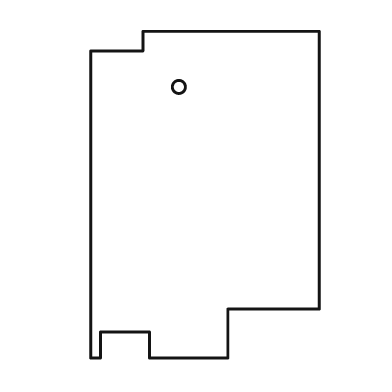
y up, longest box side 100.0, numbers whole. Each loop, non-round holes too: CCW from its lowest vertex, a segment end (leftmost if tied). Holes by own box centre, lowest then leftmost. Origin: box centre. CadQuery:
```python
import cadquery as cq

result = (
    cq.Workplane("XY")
    .moveTo(-35.0, -50.0)
    .lineTo(-32.0, -50.0)
    .lineTo(-32.0, -42.0)
    .lineTo(-17.0, -42.0)
    .lineTo(-17.0, -50.0)
    .lineTo(7.0, -50.0)
    .lineTo(7.0, -35.0)
    .lineTo(35.0, -35.0)
    .lineTo(35.0, 50.0)
    .lineTo(-19.0, 50.0)
    .lineTo(-19.0, 44.0)
    .lineTo(-35.0, 44.0)
    .close()
    .moveTo(-8.0, 33.0)
    .circle(2.0)
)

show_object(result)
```